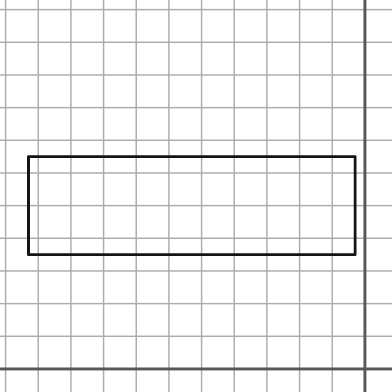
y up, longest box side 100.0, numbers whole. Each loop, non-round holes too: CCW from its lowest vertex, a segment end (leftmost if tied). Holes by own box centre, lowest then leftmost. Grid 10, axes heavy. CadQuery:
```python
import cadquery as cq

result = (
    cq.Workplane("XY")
    .moveTo(-103.0, 35.0)
    .lineTo(-3.0, 35.0)
    .lineTo(-3.0, 65.0)
    .lineTo(-103.0, 65.0)
    .close()
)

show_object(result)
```